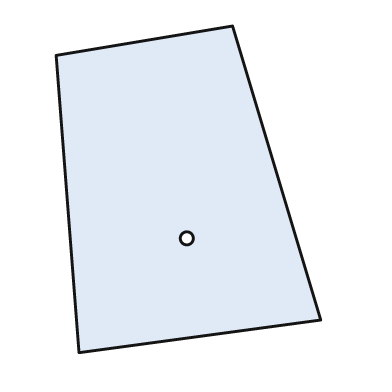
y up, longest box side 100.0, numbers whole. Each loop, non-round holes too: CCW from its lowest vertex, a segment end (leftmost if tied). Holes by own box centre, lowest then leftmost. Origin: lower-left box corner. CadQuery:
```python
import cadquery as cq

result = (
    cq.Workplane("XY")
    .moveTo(7.0, 0.0)
    .lineTo(81.0, 10.0)
    .lineTo(54.0, 100.0)
    .lineTo(0.0, 91.0)
    .close()
    .moveTo(40.0, 35.0)
    .circle(2.0)
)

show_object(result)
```